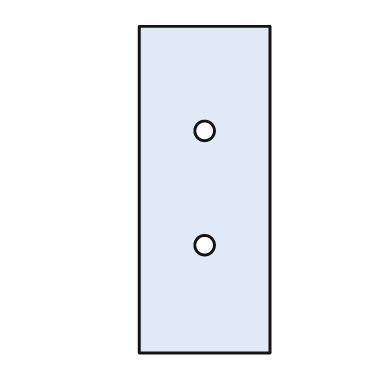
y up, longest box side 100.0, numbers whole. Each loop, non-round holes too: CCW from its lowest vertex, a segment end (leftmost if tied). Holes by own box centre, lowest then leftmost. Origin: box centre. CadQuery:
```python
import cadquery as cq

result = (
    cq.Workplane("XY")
    .moveTo(-20.0, -50.0)
    .lineTo(20.0, -50.0)
    .lineTo(20.0, 50.0)
    .lineTo(-20.0, 50.0)
    .close()
    .moveTo(0.0, -17.0)
    .circle(3.0)
    .moveTo(0.0, 18.0)
    .circle(3.0)
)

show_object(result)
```